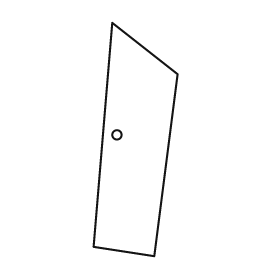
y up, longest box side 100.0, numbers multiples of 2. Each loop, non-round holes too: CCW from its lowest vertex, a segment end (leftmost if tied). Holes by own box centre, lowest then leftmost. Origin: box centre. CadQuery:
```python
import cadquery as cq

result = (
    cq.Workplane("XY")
    .moveTo(8.0, -50.0)
    .lineTo(18.0, 28.0)
    .lineTo(-10.0, 50.0)
    .lineTo(-18.0, -46.0)
    .close()
    .moveTo(-8.0, 2.0)
    .circle(2.0)
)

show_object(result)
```